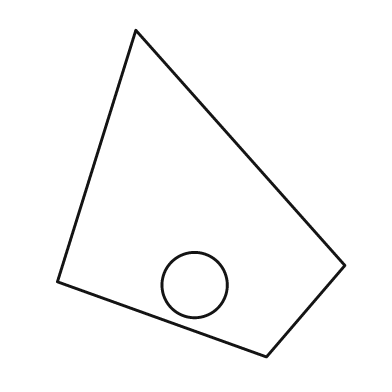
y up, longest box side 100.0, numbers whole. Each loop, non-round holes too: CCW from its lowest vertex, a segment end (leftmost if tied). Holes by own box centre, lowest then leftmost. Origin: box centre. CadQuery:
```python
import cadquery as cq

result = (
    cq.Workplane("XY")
    .moveTo(20.0, -50.0)
    .lineTo(44.0, -22.0)
    .lineTo(-20.0, 50.0)
    .lineTo(-44.0, -27.0)
    .close()
    .moveTo(-2.0, -28.0)
    .circle(10.0)
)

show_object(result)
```